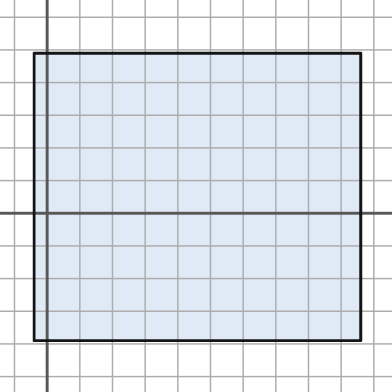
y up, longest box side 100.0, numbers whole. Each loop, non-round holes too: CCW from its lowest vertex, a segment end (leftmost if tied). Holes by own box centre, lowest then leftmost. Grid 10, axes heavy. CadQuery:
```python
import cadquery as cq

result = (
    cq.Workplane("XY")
    .moveTo(-4.0, -39.0)
    .lineTo(96.0, -39.0)
    .lineTo(96.0, 49.0)
    .lineTo(-4.0, 49.0)
    .close()
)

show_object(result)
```